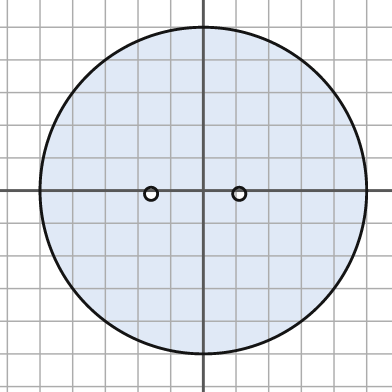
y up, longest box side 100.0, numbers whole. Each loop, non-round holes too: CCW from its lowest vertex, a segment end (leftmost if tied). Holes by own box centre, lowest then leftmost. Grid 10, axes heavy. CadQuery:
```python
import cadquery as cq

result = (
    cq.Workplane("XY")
    .moveTo(0.0, 0.0)
    .circle(50.0)
    .moveTo(-16.0, -1.0)
    .circle(2.0)
    .moveTo(11.0, -1.0)
    .circle(2.0)
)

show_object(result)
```